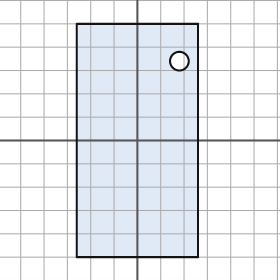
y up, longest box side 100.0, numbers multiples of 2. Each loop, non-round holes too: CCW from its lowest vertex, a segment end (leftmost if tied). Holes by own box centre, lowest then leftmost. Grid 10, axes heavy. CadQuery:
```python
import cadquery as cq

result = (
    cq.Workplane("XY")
    .moveTo(-26.0, -50.0)
    .lineTo(26.0, -50.0)
    .lineTo(26.0, 50.0)
    .lineTo(-26.0, 50.0)
    .close()
    .moveTo(18.0, 34.0)
    .circle(4.0)
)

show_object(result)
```